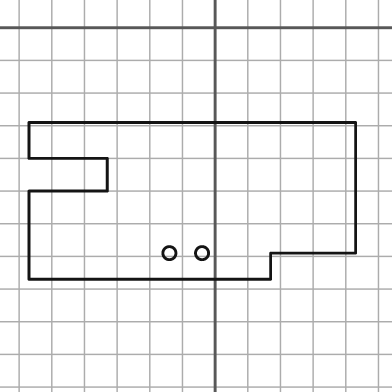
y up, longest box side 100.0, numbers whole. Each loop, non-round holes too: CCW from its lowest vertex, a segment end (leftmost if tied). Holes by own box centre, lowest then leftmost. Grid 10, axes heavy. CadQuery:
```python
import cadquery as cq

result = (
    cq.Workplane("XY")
    .moveTo(-57.0, -77.0)
    .lineTo(17.0, -77.0)
    .lineTo(17.0, -69.0)
    .lineTo(43.0, -69.0)
    .lineTo(43.0, -29.0)
    .lineTo(-57.0, -29.0)
    .lineTo(-57.0, -40.0)
    .lineTo(-33.0, -40.0)
    .lineTo(-33.0, -50.0)
    .lineTo(-57.0, -50.0)
    .close()
    .moveTo(-14.0, -69.0)
    .circle(2.0)
    .moveTo(-4.0, -69.0)
    .circle(2.0)
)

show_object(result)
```